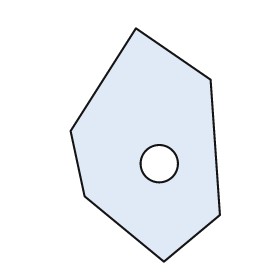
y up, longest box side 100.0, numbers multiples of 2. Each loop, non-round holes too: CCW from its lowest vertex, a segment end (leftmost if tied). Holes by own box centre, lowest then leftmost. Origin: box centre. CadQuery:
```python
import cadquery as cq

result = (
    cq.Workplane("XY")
    .moveTo(8.0, -50.0)
    .lineTo(32.0, -30.0)
    .lineTo(28.0, 28.0)
    .lineTo(-4.0, 50.0)
    .lineTo(-32.0, 6.0)
    .lineTo(-26.0, -22.0)
    .close()
    .moveTo(6.0, -8.0)
    .circle(8.0)
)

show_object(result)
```